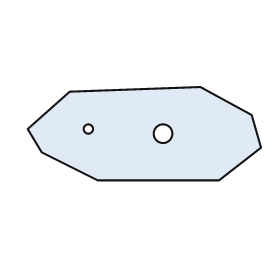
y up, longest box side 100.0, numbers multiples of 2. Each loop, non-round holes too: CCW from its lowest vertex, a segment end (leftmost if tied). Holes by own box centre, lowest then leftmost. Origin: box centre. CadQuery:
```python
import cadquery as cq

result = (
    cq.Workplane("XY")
    .moveTo(-20.0, -20.0)
    .lineTo(32.0, -20.0)
    .lineTo(50.0, -6.0)
    .lineTo(46.0, 8.0)
    .lineTo(24.0, 20.0)
    .lineTo(-32.0, 18.0)
    .lineTo(-50.0, 2.0)
    .lineTo(-44.0, -8.0)
    .close()
    .moveTo(8.0, 0.0)
    .circle(4.0)
    .moveTo(-24.0, 2.0)
    .circle(2.0)
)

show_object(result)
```